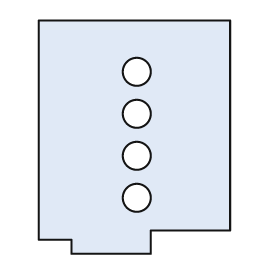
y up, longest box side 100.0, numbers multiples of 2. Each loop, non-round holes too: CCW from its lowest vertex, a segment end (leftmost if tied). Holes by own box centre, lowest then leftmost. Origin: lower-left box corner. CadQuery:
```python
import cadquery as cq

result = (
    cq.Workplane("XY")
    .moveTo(14.0, 0.0)
    .lineTo(48.0, 0.0)
    .lineTo(48.0, 10.0)
    .lineTo(82.0, 10.0)
    .lineTo(82.0, 100.0)
    .lineTo(0.0, 100.0)
    .lineTo(0.0, 6.0)
    .lineTo(14.0, 6.0)
    .close()
    .moveTo(42.0, 24.0)
    .circle(6.0)
    .moveTo(42.0, 42.0)
    .circle(6.0)
    .moveTo(42.0, 60.0)
    .circle(6.0)
    .moveTo(42.0, 78.0)
    .circle(6.0)
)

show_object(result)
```